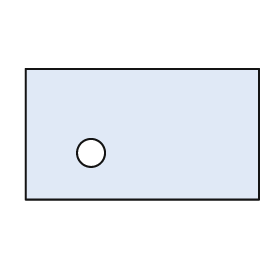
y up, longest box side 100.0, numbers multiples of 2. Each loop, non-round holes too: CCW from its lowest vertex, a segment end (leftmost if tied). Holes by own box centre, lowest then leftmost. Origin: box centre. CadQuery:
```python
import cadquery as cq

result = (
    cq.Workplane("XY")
    .moveTo(-50.0, -28.0)
    .lineTo(50.0, -28.0)
    .lineTo(50.0, 28.0)
    .lineTo(-50.0, 28.0)
    .close()
    .moveTo(-22.0, -8.0)
    .circle(6.0)
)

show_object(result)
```